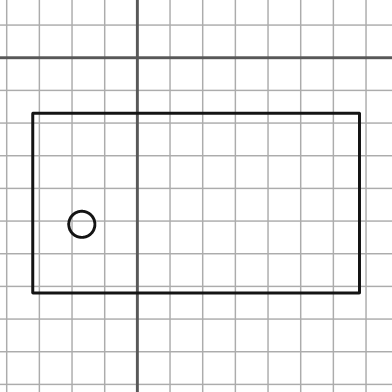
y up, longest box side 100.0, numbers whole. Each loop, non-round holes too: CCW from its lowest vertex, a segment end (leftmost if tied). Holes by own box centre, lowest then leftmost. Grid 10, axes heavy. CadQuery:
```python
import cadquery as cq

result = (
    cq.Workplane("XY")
    .moveTo(-32.0, -72.0)
    .lineTo(68.0, -72.0)
    .lineTo(68.0, -17.0)
    .lineTo(-32.0, -17.0)
    .close()
    .moveTo(-17.0, -51.0)
    .circle(4.0)
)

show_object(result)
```